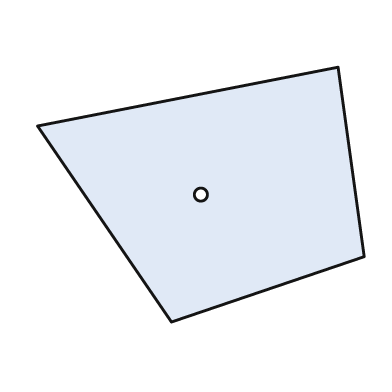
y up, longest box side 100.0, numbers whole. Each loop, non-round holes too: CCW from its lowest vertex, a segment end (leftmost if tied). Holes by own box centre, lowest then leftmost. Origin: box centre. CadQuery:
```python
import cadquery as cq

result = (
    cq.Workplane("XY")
    .moveTo(-9.0, -39.0)
    .lineTo(50.0, -19.0)
    .lineTo(42.0, 39.0)
    .lineTo(-50.0, 21.0)
    .close()
    .moveTo(0.0, 0.0)
    .circle(2.0)
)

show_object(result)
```